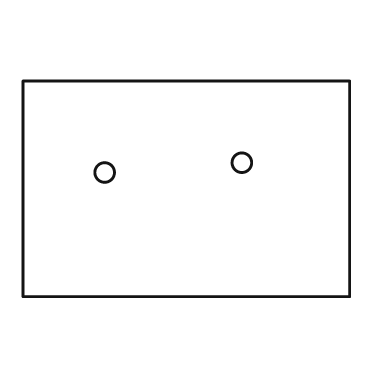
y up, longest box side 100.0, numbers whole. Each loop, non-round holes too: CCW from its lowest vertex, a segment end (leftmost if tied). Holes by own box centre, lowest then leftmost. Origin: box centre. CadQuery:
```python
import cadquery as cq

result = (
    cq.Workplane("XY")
    .moveTo(-50.0, -33.0)
    .lineTo(50.0, -33.0)
    .lineTo(50.0, 33.0)
    .lineTo(-50.0, 33.0)
    .close()
    .moveTo(-25.0, 5.0)
    .circle(3.0)
    .moveTo(17.0, 8.0)
    .circle(3.0)
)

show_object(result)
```